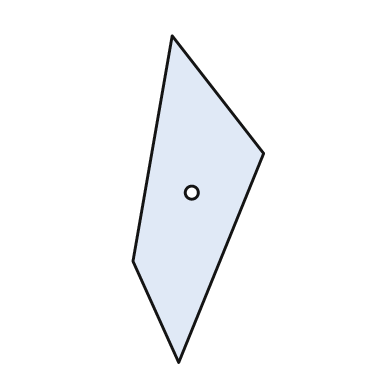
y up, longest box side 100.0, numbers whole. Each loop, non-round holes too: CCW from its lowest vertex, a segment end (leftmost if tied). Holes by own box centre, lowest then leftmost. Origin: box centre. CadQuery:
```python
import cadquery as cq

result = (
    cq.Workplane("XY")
    .moveTo(-6.0, -50.0)
    .lineTo(20.0, 14.0)
    .lineTo(-8.0, 50.0)
    .lineTo(-20.0, -19.0)
    .close()
    .moveTo(-2.0, 2.0)
    .circle(2.0)
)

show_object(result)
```